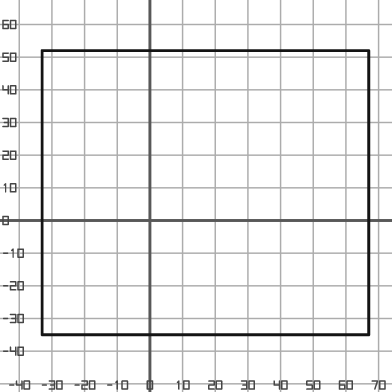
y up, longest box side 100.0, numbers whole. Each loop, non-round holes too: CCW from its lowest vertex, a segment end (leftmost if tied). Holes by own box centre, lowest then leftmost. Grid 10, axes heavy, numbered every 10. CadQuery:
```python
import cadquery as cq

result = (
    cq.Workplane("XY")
    .moveTo(-33.0, -35.0)
    .lineTo(67.0, -35.0)
    .lineTo(67.0, 52.0)
    .lineTo(-33.0, 52.0)
    .close()
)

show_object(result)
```